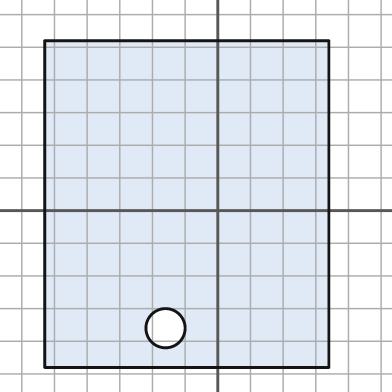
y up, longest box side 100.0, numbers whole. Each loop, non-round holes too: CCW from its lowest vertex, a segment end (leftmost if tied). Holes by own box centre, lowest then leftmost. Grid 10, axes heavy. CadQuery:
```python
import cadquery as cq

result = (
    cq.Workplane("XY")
    .moveTo(-53.0, -48.0)
    .lineTo(34.0, -48.0)
    .lineTo(34.0, 52.0)
    .lineTo(-53.0, 52.0)
    .close()
    .moveTo(-16.0, -36.0)
    .circle(6.0)
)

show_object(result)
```